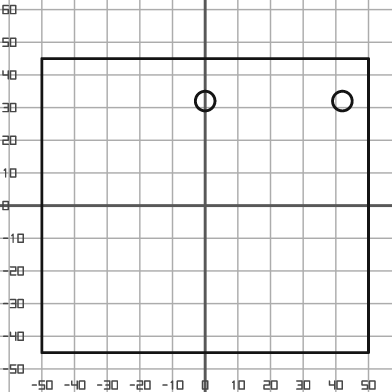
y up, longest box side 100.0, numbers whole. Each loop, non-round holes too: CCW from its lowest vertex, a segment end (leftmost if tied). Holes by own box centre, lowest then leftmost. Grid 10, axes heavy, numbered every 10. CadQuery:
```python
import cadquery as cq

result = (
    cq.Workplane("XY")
    .moveTo(-50.0, -45.0)
    .lineTo(50.0, -45.0)
    .lineTo(50.0, 45.0)
    .lineTo(-50.0, 45.0)
    .close()
    .moveTo(0.0, 32.0)
    .circle(3.0)
    .moveTo(42.0, 32.0)
    .circle(3.0)
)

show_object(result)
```